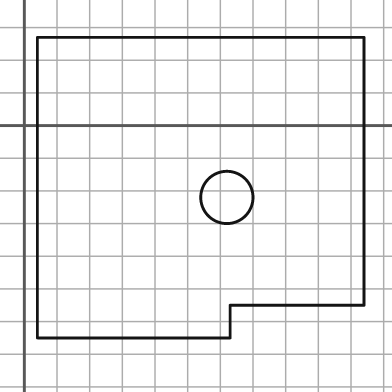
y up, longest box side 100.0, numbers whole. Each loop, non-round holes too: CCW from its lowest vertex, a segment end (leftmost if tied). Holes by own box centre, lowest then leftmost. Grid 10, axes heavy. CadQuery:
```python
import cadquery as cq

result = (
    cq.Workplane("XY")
    .moveTo(4.0, -65.0)
    .lineTo(63.0, -65.0)
    .lineTo(63.0, -55.0)
    .lineTo(104.0, -55.0)
    .lineTo(104.0, 27.0)
    .lineTo(4.0, 27.0)
    .close()
    .moveTo(62.0, -22.0)
    .circle(8.0)
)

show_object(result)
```